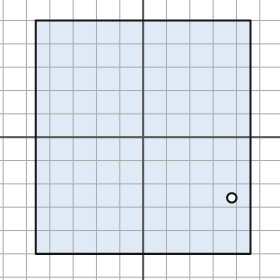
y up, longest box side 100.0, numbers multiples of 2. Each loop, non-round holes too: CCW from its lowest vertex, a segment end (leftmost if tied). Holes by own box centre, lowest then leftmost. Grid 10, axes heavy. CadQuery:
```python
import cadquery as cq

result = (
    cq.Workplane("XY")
    .moveTo(-46.0, -50.0)
    .lineTo(46.0, -50.0)
    .lineTo(46.0, 50.0)
    .lineTo(-46.0, 50.0)
    .close()
    .moveTo(38.0, -26.0)
    .circle(2.0)
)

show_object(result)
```